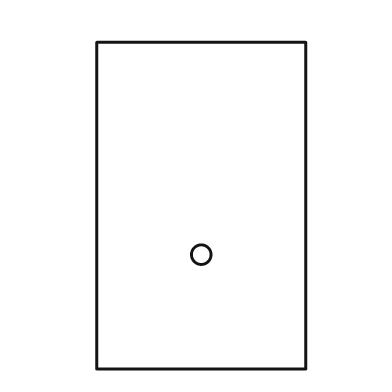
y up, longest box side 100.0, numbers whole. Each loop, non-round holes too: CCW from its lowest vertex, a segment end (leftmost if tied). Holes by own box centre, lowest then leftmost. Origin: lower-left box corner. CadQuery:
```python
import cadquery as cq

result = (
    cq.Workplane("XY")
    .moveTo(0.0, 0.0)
    .lineTo(64.0, 0.0)
    .lineTo(64.0, 100.0)
    .lineTo(0.0, 100.0)
    .close()
    .moveTo(32.0, 35.0)
    .circle(3.0)
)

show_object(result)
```